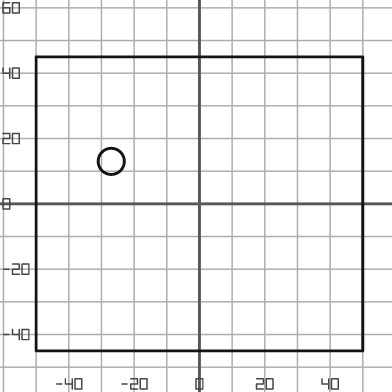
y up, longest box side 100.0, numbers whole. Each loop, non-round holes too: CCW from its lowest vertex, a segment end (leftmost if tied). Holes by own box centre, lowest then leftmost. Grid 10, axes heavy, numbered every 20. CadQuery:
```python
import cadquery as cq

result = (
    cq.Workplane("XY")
    .moveTo(-50.0, -45.0)
    .lineTo(50.0, -45.0)
    .lineTo(50.0, 45.0)
    .lineTo(-50.0, 45.0)
    .close()
    .moveTo(-27.0, 13.0)
    .circle(4.0)
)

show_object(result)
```